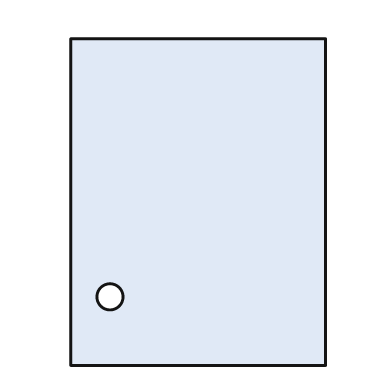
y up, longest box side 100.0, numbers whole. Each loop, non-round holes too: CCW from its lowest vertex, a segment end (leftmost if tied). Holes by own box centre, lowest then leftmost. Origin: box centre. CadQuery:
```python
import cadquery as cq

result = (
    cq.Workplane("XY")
    .moveTo(-39.0, -50.0)
    .lineTo(39.0, -50.0)
    .lineTo(39.0, 50.0)
    .lineTo(-39.0, 50.0)
    .close()
    .moveTo(-27.0, -29.0)
    .circle(4.0)
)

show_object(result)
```